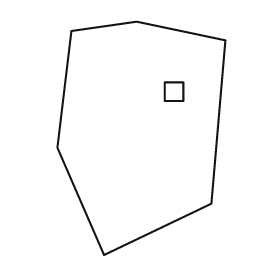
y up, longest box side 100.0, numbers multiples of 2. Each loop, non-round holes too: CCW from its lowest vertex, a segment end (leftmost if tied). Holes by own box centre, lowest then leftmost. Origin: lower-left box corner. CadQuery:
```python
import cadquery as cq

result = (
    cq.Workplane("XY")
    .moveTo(20.0, 0.0)
    .lineTo(66.0, 22.0)
    .lineTo(72.0, 92.0)
    .lineTo(34.0, 100.0)
    .lineTo(6.0, 96.0)
    .lineTo(0.0, 46.0)
    .close()
    .moveTo(46.0, 66.0)
    .lineTo(54.0, 66.0)
    .lineTo(54.0, 74.0)
    .lineTo(46.0, 74.0)
    .close()
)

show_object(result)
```